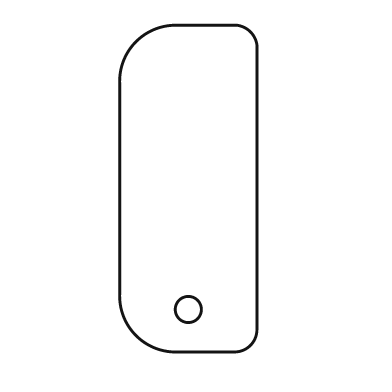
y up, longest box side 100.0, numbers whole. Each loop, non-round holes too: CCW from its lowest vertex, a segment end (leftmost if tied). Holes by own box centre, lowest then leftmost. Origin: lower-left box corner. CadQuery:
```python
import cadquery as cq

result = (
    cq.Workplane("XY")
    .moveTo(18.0, 0.0)
    .lineTo(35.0, 0.0)
    .threePointArc((40.0, 2.0), (42.0, 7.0))
    .lineTo(42.0, 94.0)
    .threePointArc((40.0, 98.0), (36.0, 100.0))
    .lineTo(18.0, 100.0)
    .threePointArc((5.0, 95.0), (0.0, 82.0))
    .lineTo(0.0, 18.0)
    .threePointArc((5.0, 5.0), (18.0, 0.0))
    .close()
    .moveTo(21.0, 13.0)
    .circle(4.0)
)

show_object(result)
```